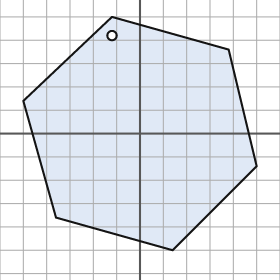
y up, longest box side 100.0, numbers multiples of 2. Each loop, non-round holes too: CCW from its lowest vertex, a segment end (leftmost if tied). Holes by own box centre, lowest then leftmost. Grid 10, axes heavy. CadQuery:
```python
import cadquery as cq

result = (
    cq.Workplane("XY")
    .moveTo(14.0, -50.0)
    .lineTo(50.0, -14.0)
    .lineTo(38.0, 36.0)
    .lineTo(-12.0, 50.0)
    .lineTo(-50.0, 14.0)
    .lineTo(-36.0, -36.0)
    .close()
    .moveTo(-12.0, 42.0)
    .circle(2.0)
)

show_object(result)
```